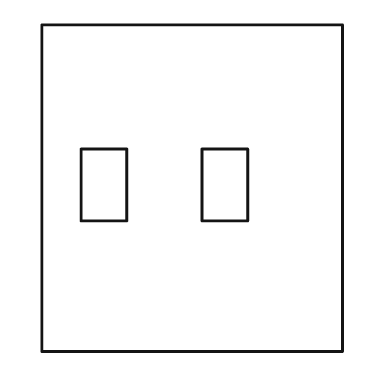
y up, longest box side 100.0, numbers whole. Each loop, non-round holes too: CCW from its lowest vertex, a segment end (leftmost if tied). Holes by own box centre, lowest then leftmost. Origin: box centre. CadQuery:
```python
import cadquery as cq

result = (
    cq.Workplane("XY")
    .moveTo(-46.0, -50.0)
    .lineTo(46.0, -50.0)
    .lineTo(46.0, 50.0)
    .lineTo(-46.0, 50.0)
    .close()
    .moveTo(-34.0, -10.0)
    .lineTo(-20.0, -10.0)
    .lineTo(-20.0, 12.0)
    .lineTo(-34.0, 12.0)
    .close()
    .moveTo(3.0, -10.0)
    .lineTo(17.0, -10.0)
    .lineTo(17.0, 12.0)
    .lineTo(3.0, 12.0)
    .close()
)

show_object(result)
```